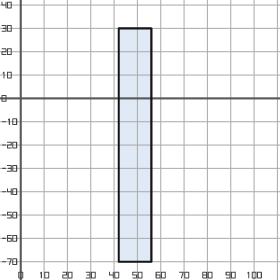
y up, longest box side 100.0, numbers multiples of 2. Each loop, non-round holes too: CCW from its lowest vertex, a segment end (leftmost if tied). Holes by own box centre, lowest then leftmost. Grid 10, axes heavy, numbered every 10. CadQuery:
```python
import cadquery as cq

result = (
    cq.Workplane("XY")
    .moveTo(42.0, -70.0)
    .lineTo(56.0, -70.0)
    .lineTo(56.0, 30.0)
    .lineTo(42.0, 30.0)
    .close()
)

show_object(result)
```